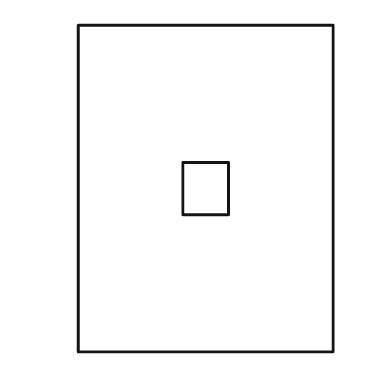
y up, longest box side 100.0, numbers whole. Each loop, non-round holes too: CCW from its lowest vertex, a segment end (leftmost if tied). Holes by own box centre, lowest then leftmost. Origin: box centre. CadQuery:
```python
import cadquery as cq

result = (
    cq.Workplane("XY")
    .moveTo(-39.0, -50.0)
    .lineTo(39.0, -50.0)
    .lineTo(39.0, 50.0)
    .lineTo(-39.0, 50.0)
    .close()
    .moveTo(-7.0, -8.0)
    .lineTo(7.0, -8.0)
    .lineTo(7.0, 8.0)
    .lineTo(-7.0, 8.0)
    .close()
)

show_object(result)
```